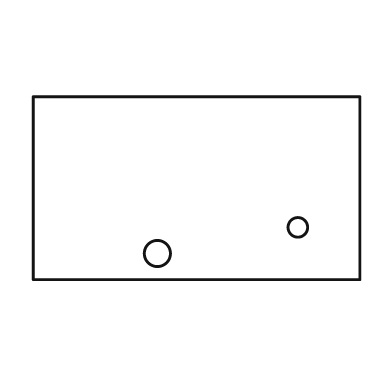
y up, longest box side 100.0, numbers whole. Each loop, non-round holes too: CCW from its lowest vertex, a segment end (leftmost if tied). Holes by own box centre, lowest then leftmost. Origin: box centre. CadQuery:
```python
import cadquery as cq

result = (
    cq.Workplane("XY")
    .moveTo(-50.0, -28.0)
    .lineTo(50.0, -28.0)
    .lineTo(50.0, 28.0)
    .lineTo(-50.0, 28.0)
    .close()
    .moveTo(-12.0, -20.0)
    .circle(4.0)
    .moveTo(31.0, -12.0)
    .circle(3.0)
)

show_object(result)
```